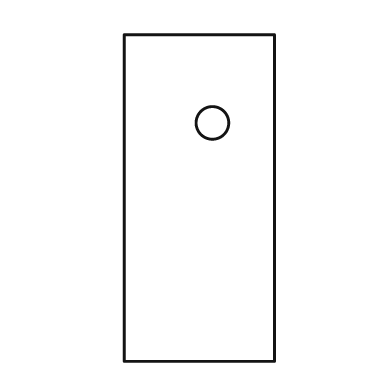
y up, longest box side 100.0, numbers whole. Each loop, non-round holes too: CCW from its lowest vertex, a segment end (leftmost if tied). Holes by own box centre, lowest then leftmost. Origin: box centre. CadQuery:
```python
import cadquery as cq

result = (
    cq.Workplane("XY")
    .moveTo(-23.0, -50.0)
    .lineTo(23.0, -50.0)
    .lineTo(23.0, 50.0)
    .lineTo(-23.0, 50.0)
    .close()
    .moveTo(4.0, 23.0)
    .circle(5.0)
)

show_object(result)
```